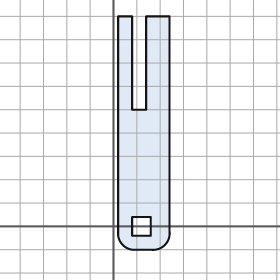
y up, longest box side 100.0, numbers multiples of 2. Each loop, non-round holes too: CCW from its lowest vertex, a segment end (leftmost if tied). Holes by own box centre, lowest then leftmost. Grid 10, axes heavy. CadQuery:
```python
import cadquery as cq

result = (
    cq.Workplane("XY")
    .moveTo(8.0, -10.0)
    .lineTo(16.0, -10.0)
    .threePointArc((22.0, -8.0), (24.0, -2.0))
    .lineTo(24.0, 90.0)
    .lineTo(14.0, 90.0)
    .lineTo(14.0, 50.0)
    .lineTo(8.0, 50.0)
    .lineTo(8.0, 90.0)
    .lineTo(2.0, 90.0)
    .lineTo(2.0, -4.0)
    .threePointArc((4.0, -8.0), (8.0, -10.0))
    .close()
    .moveTo(8.0, -4.0)
    .lineTo(16.0, -4.0)
    .lineTo(16.0, 4.0)
    .lineTo(8.0, 4.0)
    .close()
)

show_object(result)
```